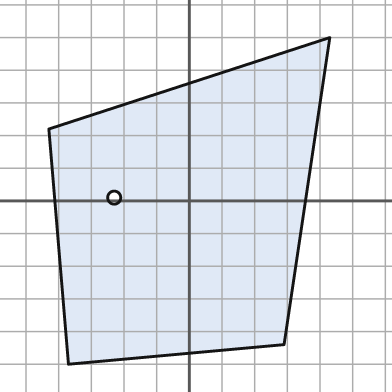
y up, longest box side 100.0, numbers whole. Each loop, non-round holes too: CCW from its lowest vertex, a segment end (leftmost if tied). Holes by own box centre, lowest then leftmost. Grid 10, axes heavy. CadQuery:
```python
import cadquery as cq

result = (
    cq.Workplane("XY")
    .moveTo(-37.0, -50.0)
    .lineTo(29.0, -44.0)
    .lineTo(43.0, 50.0)
    .lineTo(-43.0, 22.0)
    .close()
    .moveTo(-23.0, 1.0)
    .circle(2.0)
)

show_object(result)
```